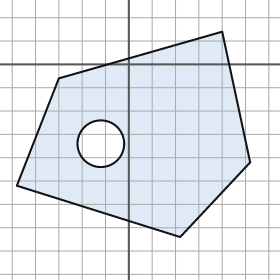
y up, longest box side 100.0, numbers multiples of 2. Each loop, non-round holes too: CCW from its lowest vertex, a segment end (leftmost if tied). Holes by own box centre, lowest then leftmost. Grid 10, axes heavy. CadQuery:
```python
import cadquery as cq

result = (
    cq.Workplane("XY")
    .moveTo(22.0, -74.0)
    .lineTo(52.0, -42.0)
    .lineTo(40.0, 14.0)
    .lineTo(-30.0, -6.0)
    .lineTo(-48.0, -52.0)
    .close()
    .moveTo(-12.0, -34.0)
    .circle(10.0)
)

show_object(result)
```